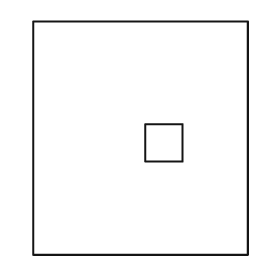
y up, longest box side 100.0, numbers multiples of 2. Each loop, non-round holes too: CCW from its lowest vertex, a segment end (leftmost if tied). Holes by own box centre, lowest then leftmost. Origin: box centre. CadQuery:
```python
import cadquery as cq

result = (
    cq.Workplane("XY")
    .moveTo(-46.0, -50.0)
    .lineTo(46.0, -50.0)
    .lineTo(46.0, 50.0)
    .lineTo(-46.0, 50.0)
    .close()
    .moveTo(2.0, -10.0)
    .lineTo(18.0, -10.0)
    .lineTo(18.0, 6.0)
    .lineTo(2.0, 6.0)
    .close()
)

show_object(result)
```